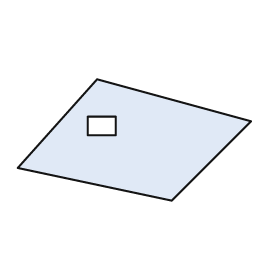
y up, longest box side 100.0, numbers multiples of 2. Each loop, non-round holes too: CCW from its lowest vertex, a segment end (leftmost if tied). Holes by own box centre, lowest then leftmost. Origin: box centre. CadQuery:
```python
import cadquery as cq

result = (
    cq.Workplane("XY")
    .moveTo(16.0, -26.0)
    .lineTo(50.0, 8.0)
    .lineTo(-16.0, 26.0)
    .lineTo(-50.0, -12.0)
    .close()
    .moveTo(-20.0, 2.0)
    .lineTo(-8.0, 2.0)
    .lineTo(-8.0, 10.0)
    .lineTo(-20.0, 10.0)
    .close()
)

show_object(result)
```